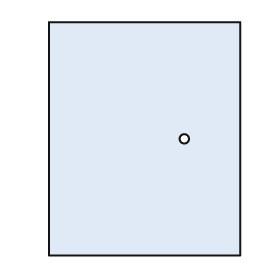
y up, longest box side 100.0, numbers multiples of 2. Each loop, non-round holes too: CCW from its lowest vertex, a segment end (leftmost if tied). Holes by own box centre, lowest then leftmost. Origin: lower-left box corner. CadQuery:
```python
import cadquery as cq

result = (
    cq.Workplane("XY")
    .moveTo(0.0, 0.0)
    .lineTo(82.0, 0.0)
    .lineTo(82.0, 100.0)
    .lineTo(0.0, 100.0)
    .close()
    .moveTo(58.0, 50.0)
    .circle(2.0)
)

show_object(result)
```